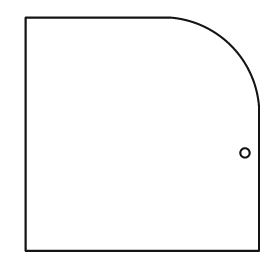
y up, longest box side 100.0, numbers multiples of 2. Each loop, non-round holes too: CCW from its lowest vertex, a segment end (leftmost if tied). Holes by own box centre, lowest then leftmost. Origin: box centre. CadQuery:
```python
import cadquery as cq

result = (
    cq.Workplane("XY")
    .moveTo(-50.0, -50.0)
    .lineTo(50.0, -50.0)
    .lineTo(50.0, 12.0)
    .threePointArc((38.0, 38.0), (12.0, 50.0))
    .lineTo(-50.0, 50.0)
    .close()
    .moveTo(44.0, -8.0)
    .circle(2.0)
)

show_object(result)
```